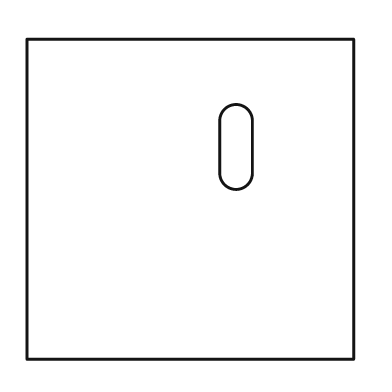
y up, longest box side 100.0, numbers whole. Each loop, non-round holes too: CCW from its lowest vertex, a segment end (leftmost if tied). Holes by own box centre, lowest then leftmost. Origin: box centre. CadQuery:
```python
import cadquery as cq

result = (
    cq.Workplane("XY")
    .moveTo(-50.0, -49.0)
    .lineTo(50.0, -49.0)
    .lineTo(50.0, 49.0)
    .lineTo(-50.0, 49.0)
    .close()
    .moveTo(9.0, 8.0)
    .threePointArc((14.0, 3.0), (19.0, 8.0))
    .lineTo(19.0, 24.0)
    .threePointArc((14.0, 29.0), (9.0, 24.0))
    .close()
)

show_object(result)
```